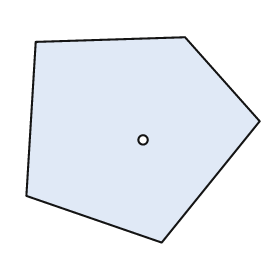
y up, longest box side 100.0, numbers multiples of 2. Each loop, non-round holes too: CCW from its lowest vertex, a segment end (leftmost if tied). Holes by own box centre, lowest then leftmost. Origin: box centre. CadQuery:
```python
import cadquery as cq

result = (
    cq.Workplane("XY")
    .moveTo(8.0, -44.0)
    .lineTo(50.0, 8.0)
    .lineTo(18.0, 44.0)
    .lineTo(-46.0, 42.0)
    .lineTo(-50.0, -24.0)
    .close()
    .moveTo(0.0, 0.0)
    .circle(2.0)
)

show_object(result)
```